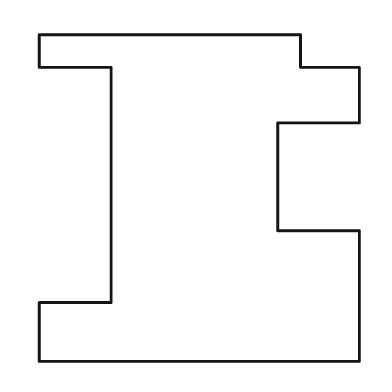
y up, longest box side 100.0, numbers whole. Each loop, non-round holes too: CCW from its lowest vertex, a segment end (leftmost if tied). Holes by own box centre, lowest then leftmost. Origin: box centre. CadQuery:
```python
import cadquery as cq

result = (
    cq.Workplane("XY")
    .moveTo(-49.0, -50.0)
    .lineTo(49.0, -50.0)
    .lineTo(49.0, -10.0)
    .lineTo(24.0, -10.0)
    .lineTo(24.0, 23.0)
    .lineTo(49.0, 23.0)
    .lineTo(49.0, 40.0)
    .lineTo(31.0, 40.0)
    .lineTo(31.0, 50.0)
    .lineTo(-49.0, 50.0)
    .lineTo(-49.0, 40.0)
    .lineTo(-27.0, 40.0)
    .lineTo(-27.0, -32.0)
    .lineTo(-49.0, -32.0)
    .close()
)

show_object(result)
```